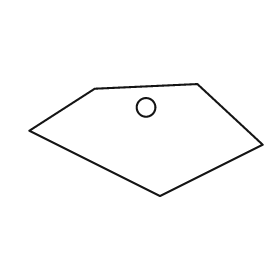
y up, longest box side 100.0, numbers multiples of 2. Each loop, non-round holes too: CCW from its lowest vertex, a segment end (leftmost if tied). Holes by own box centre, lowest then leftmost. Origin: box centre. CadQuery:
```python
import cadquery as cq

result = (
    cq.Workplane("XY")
    .moveTo(6.0, -24.0)
    .lineTo(50.0, -2.0)
    .lineTo(22.0, 24.0)
    .lineTo(-22.0, 22.0)
    .lineTo(-50.0, 4.0)
    .close()
    .moveTo(0.0, 14.0)
    .circle(4.0)
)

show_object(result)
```